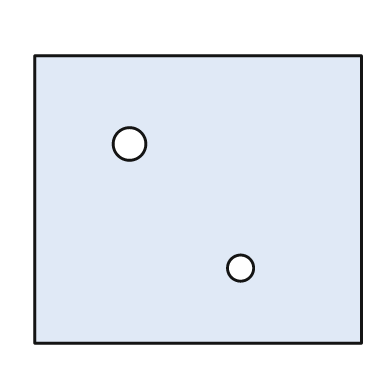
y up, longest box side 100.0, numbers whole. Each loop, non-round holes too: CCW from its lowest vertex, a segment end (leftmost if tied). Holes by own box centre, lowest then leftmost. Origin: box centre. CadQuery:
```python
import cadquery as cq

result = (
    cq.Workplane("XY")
    .moveTo(-50.0, -44.0)
    .lineTo(50.0, -44.0)
    .lineTo(50.0, 44.0)
    .lineTo(-50.0, 44.0)
    .close()
    .moveTo(13.0, -21.0)
    .circle(4.0)
    .moveTo(-21.0, 17.0)
    .circle(5.0)
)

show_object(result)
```